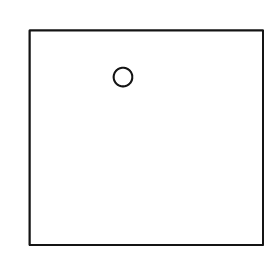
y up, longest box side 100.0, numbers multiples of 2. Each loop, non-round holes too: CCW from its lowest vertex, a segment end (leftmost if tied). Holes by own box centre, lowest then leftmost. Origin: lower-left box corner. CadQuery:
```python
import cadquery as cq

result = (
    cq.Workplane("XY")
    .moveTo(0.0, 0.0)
    .lineTo(100.0, 0.0)
    .lineTo(100.0, 92.0)
    .lineTo(0.0, 92.0)
    .close()
    .moveTo(40.0, 72.0)
    .circle(4.0)
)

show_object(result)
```